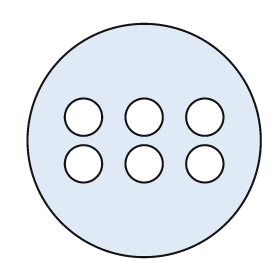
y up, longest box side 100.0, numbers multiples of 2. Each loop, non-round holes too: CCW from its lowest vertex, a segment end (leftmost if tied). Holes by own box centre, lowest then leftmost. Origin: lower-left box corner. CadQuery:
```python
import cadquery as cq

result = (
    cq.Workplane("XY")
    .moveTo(50.0, 50.0)
    .circle(50.0)
    .moveTo(24.0, 40.0)
    .circle(8.0)
    .moveTo(50.0, 40.0)
    .circle(8.0)
    .moveTo(76.0, 40.0)
    .circle(8.0)
    .moveTo(24.0, 60.0)
    .circle(8.0)
    .moveTo(50.0, 60.0)
    .circle(8.0)
    .moveTo(76.0, 60.0)
    .circle(8.0)
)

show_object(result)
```